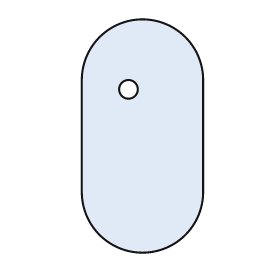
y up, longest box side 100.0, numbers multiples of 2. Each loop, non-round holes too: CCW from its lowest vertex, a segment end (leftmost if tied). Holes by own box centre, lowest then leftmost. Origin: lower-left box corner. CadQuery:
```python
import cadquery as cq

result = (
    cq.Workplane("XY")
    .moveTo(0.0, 26.0)
    .threePointArc((26.0, 0.0), (52.0, 26.0))
    .lineTo(52.0, 74.0)
    .threePointArc((26.0, 100.0), (0.0, 74.0))
    .close()
    .moveTo(20.0, 70.0)
    .circle(4.0)
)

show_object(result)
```